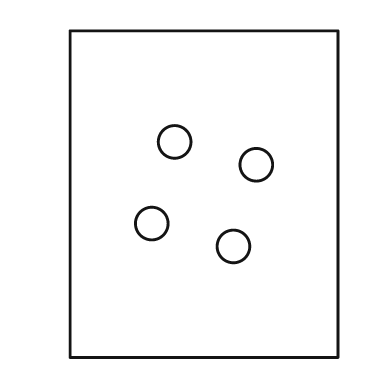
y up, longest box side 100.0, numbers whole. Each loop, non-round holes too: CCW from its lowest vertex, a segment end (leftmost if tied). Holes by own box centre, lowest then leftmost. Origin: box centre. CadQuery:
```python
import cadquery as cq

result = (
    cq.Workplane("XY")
    .moveTo(-41.0, -50.0)
    .lineTo(41.0, -50.0)
    .lineTo(41.0, 50.0)
    .lineTo(-41.0, 50.0)
    .close()
    .moveTo(9.0, -16.0)
    .circle(5.0)
    .moveTo(-16.0, -9.0)
    .circle(5.0)
    .moveTo(16.0, 9.0)
    .circle(5.0)
    .moveTo(-9.0, 16.0)
    .circle(5.0)
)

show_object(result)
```